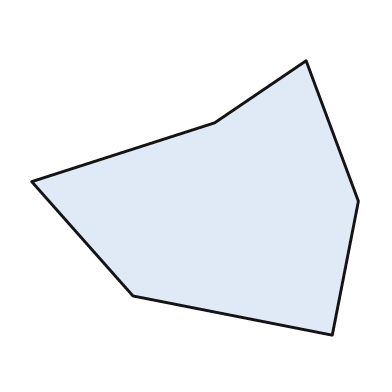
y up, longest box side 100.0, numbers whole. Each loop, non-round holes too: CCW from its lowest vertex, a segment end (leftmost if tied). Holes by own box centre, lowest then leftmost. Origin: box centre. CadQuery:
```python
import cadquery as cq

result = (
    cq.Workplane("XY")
    .moveTo(42.0, -42.0)
    .lineTo(50.0, -1.0)
    .lineTo(34.0, 42.0)
    .lineTo(6.0, 23.0)
    .lineTo(-50.0, 5.0)
    .lineTo(-19.0, -30.0)
    .close()
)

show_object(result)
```